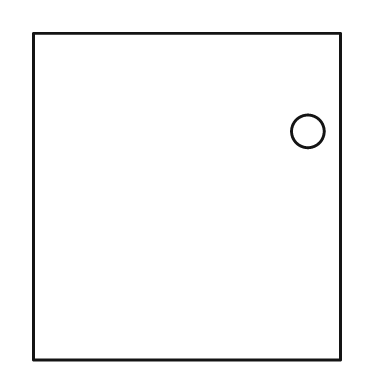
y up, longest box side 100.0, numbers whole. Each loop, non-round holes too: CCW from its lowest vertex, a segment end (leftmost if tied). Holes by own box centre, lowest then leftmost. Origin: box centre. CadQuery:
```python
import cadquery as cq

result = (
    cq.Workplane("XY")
    .moveTo(-47.0, -50.0)
    .lineTo(47.0, -50.0)
    .lineTo(47.0, 50.0)
    .lineTo(-47.0, 50.0)
    .close()
    .moveTo(37.0, 20.0)
    .circle(5.0)
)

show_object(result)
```